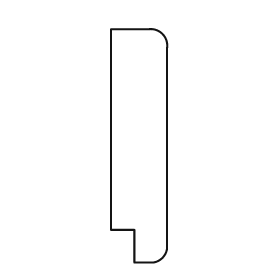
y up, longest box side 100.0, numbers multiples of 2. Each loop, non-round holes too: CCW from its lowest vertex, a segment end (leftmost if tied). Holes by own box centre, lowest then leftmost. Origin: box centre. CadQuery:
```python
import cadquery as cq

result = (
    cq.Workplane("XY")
    .moveTo(-2.0, -50.0)
    .lineTo(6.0, -50.0)
    .threePointArc((10.0, -48.0), (12.0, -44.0))
    .lineTo(12.0, 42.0)
    .threePointArc((10.0, 48.0), (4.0, 50.0))
    .lineTo(-12.0, 50.0)
    .lineTo(-12.0, -36.0)
    .lineTo(-2.0, -36.0)
    .close()
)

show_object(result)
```